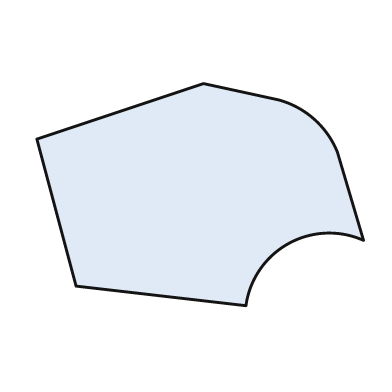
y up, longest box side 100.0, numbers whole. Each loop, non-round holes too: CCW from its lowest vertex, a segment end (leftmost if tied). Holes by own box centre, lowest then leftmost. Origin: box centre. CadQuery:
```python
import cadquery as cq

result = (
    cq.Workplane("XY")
    .moveTo(14.0, -34.0)
    .threePointArc((27.0, -15.0), (50.0, -14.0))
    .lineTo(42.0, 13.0)
    .threePointArc((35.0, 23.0), (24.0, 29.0))
    .lineTo(1.0, 34.0)
    .lineTo(-50.0, 17.0)
    .lineTo(-38.0, -28.0)
    .close()
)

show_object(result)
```